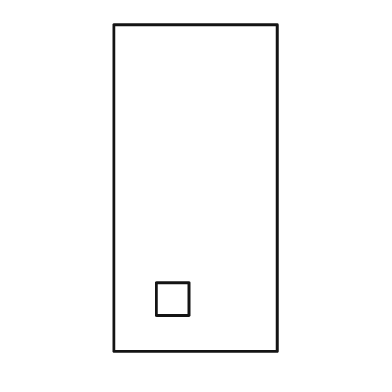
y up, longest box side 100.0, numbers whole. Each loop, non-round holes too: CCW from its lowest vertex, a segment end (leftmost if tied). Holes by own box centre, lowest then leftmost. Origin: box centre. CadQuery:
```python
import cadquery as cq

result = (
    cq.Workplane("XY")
    .moveTo(-25.0, -50.0)
    .lineTo(25.0, -50.0)
    .lineTo(25.0, 50.0)
    .lineTo(-25.0, 50.0)
    .close()
    .moveTo(-12.0, -39.0)
    .lineTo(-2.0, -39.0)
    .lineTo(-2.0, -29.0)
    .lineTo(-12.0, -29.0)
    .close()
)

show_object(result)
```